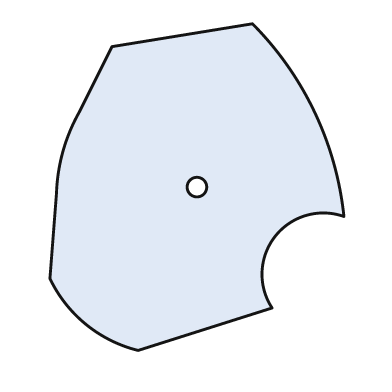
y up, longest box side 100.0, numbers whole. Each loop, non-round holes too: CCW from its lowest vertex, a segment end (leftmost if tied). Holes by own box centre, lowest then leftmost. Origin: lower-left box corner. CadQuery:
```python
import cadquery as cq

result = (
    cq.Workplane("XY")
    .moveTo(27.0, 0.0)
    .lineTo(68.0, 13.0)
    .threePointArc((69.0, 35.0), (90.0, 41.0))
    .threePointArc((81.0, 73.0), (62.0, 100.0))
    .lineTo(19.0, 93.0)
    .lineTo(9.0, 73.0)
    .threePointArc((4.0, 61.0), (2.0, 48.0))
    .lineTo(0.0, 22.0)
    .threePointArc((11.0, 8.0), (27.0, 0.0))
    .close()
    .moveTo(45.0, 50.0)
    .circle(3.0)
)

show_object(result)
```